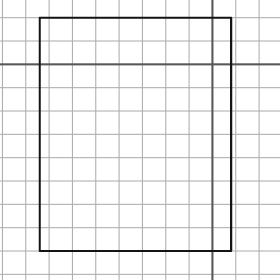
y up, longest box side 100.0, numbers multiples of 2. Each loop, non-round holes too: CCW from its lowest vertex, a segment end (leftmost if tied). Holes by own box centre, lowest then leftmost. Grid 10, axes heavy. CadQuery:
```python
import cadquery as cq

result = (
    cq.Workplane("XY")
    .moveTo(-74.0, -80.0)
    .lineTo(8.0, -80.0)
    .lineTo(8.0, 20.0)
    .lineTo(-74.0, 20.0)
    .close()
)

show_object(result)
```